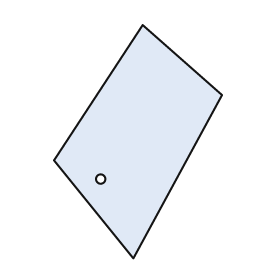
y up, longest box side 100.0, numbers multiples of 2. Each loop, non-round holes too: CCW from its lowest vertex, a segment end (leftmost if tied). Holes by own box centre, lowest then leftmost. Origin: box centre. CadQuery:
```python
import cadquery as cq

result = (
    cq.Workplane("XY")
    .moveTo(-2.0, -50.0)
    .lineTo(36.0, 20.0)
    .lineTo(2.0, 50.0)
    .lineTo(-36.0, -8.0)
    .close()
    .moveTo(-16.0, -16.0)
    .circle(2.0)
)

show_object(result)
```